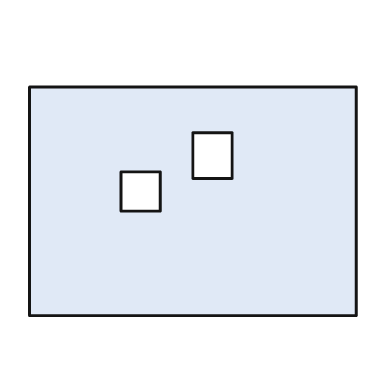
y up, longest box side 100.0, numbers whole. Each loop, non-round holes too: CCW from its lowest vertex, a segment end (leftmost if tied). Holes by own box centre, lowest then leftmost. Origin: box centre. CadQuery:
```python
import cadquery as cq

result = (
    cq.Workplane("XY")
    .moveTo(-50.0, -35.0)
    .lineTo(50.0, -35.0)
    .lineTo(50.0, 35.0)
    .lineTo(-50.0, 35.0)
    .close()
    .moveTo(-22.0, -3.0)
    .lineTo(-10.0, -3.0)
    .lineTo(-10.0, 9.0)
    .lineTo(-22.0, 9.0)
    .close()
    .moveTo(0.0, 7.0)
    .lineTo(12.0, 7.0)
    .lineTo(12.0, 21.0)
    .lineTo(0.0, 21.0)
    .close()
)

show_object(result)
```